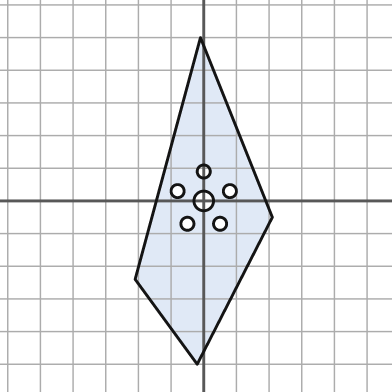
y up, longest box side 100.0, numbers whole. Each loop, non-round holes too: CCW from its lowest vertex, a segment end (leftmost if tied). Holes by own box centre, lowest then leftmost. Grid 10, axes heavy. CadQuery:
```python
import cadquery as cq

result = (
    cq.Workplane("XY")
    .moveTo(-2.0, -50.0)
    .lineTo(21.0, -5.0)
    .lineTo(-1.0, 50.0)
    .lineTo(-21.0, -24.0)
    .close()
    .moveTo(-5.0, -7.0)
    .circle(2.0)
    .moveTo(5.0, -7.0)
    .circle(2.0)
    .moveTo(0.0, 0.0)
    .circle(3.0)
    .moveTo(-8.0, 3.0)
    .circle(2.0)
    .moveTo(8.0, 3.0)
    .circle(2.0)
    .moveTo(0.0, 9.0)
    .circle(2.0)
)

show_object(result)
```